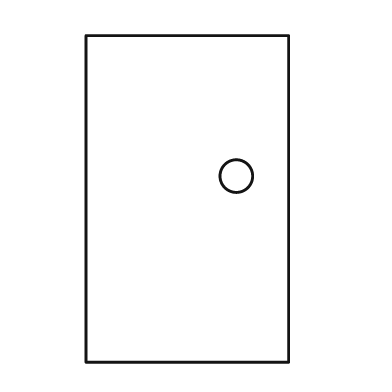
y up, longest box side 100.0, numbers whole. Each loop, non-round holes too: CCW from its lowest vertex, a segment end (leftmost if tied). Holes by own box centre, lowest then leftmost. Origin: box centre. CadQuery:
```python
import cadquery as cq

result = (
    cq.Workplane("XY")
    .moveTo(-31.0, -50.0)
    .lineTo(31.0, -50.0)
    .lineTo(31.0, 50.0)
    .lineTo(-31.0, 50.0)
    .close()
    .moveTo(15.0, 7.0)
    .circle(5.0)
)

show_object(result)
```